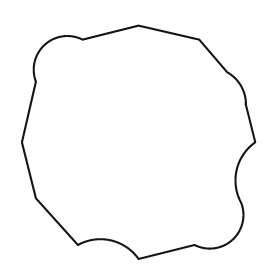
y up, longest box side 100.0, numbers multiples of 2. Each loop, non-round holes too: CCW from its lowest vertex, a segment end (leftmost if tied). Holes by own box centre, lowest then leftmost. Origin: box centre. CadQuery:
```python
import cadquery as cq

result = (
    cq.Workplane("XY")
    .moveTo(0.0, -50.0)
    .lineTo(24.0, -44.0)
    .threePointArc((40.0, -42.0), (44.0, -26.0))
    .threePointArc((42.0, -12.0), (50.0, 0.0))
    .lineTo(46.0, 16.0)
    .threePointArc((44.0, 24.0), (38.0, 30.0))
    .lineTo(26.0, 44.0)
    .lineTo(0.0, 50.0)
    .lineTo(-24.0, 44.0)
    .threePointArc((-40.0, 42.0), (-44.0, 26.0))
    .lineTo(-50.0, 0.0)
    .lineTo(-44.0, -24.0)
    .lineTo(-26.0, -44.0)
    .threePointArc((-12.0, -42.0), (0.0, -50.0))
    .close()
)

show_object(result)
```